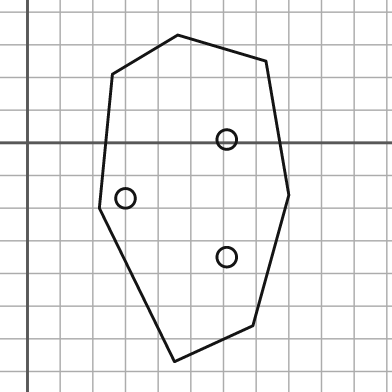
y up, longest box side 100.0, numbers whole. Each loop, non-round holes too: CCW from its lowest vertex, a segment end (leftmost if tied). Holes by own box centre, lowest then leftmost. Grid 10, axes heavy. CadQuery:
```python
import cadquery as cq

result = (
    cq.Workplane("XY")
    .moveTo(45.0, -67.0)
    .lineTo(69.0, -56.0)
    .lineTo(80.0, -16.0)
    .lineTo(73.0, 25.0)
    .lineTo(46.0, 33.0)
    .lineTo(26.0, 21.0)
    .lineTo(22.0, -20.0)
    .close()
    .moveTo(61.0, -35.0)
    .circle(3.0)
    .moveTo(30.0, -17.0)
    .circle(3.0)
    .moveTo(61.0, 1.0)
    .circle(3.0)
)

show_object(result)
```